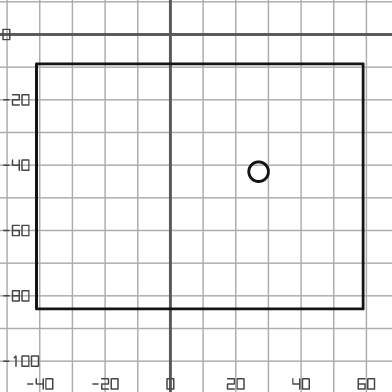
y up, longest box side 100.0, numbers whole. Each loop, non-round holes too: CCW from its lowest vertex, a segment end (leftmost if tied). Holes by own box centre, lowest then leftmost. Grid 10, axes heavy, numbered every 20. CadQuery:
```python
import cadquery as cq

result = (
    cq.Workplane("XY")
    .moveTo(-41.0, -84.0)
    .lineTo(59.0, -84.0)
    .lineTo(59.0, -9.0)
    .lineTo(-41.0, -9.0)
    .close()
    .moveTo(27.0, -42.0)
    .circle(3.0)
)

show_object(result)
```